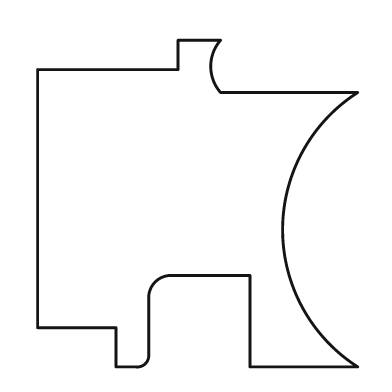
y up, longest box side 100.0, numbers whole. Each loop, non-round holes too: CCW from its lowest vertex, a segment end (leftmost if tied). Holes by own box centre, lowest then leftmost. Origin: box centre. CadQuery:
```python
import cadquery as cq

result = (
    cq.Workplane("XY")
    .moveTo(-25.0, -50.0)
    .lineTo(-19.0, -50.0)
    .threePointArc((-16.0, -49.0), (-15.0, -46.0))
    .lineTo(-15.0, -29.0)
    .threePointArc((-13.0, -24.0), (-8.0, -22.0))
    .lineTo(16.0, -22.0)
    .lineTo(16.0, -50.0)
    .lineTo(49.0, -50.0)
    .threePointArc((26.0, -8.0), (49.0, 34.0))
    .lineTo(7.0, 34.0)
    .threePointArc((4.0, 42.0), (7.0, 50.0))
    .lineTo(-6.0, 50.0)
    .lineTo(-6.0, 41.0)
    .lineTo(-49.0, 41.0)
    .lineTo(-49.0, -38.0)
    .lineTo(-25.0, -38.0)
    .close()
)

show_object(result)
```